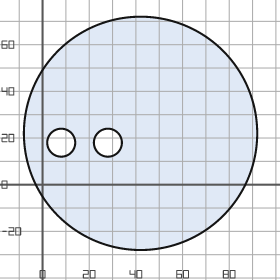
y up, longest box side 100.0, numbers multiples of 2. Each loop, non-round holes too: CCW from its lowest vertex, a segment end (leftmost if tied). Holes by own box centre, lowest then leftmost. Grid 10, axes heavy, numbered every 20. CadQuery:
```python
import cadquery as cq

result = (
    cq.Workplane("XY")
    .moveTo(42.0, 22.0)
    .circle(50.0)
    .moveTo(8.0, 18.0)
    .circle(6.0)
    .moveTo(28.0, 18.0)
    .circle(6.0)
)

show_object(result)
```